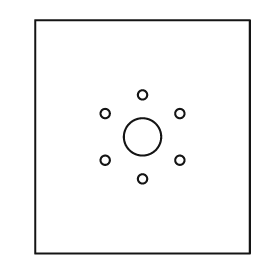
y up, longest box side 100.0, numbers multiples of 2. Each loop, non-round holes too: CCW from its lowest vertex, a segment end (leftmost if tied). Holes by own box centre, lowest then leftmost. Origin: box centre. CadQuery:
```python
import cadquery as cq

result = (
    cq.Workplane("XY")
    .moveTo(-46.0, -50.0)
    .lineTo(46.0, -50.0)
    .lineTo(46.0, 50.0)
    .lineTo(-46.0, 50.0)
    .close()
    .moveTo(0.0, -18.0)
    .circle(2.0)
    .moveTo(-16.0, -10.0)
    .circle(2.0)
    .moveTo(16.0, -10.0)
    .circle(2.0)
    .moveTo(0.0, 0.0)
    .circle(8.0)
    .moveTo(-16.0, 10.0)
    .circle(2.0)
    .moveTo(16.0, 10.0)
    .circle(2.0)
    .moveTo(0.0, 18.0)
    .circle(2.0)
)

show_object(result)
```